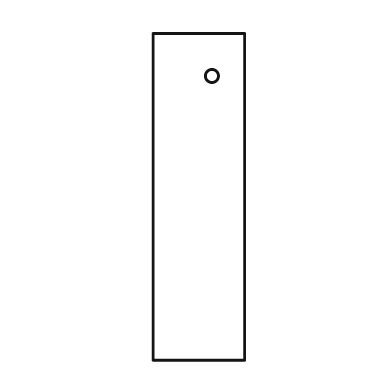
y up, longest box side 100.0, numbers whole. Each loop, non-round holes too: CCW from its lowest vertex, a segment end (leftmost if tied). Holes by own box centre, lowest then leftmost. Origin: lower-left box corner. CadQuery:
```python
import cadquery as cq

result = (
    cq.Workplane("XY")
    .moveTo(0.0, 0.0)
    .lineTo(28.0, 0.0)
    .lineTo(28.0, 100.0)
    .lineTo(0.0, 100.0)
    .close()
    .moveTo(18.0, 87.0)
    .circle(2.0)
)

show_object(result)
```